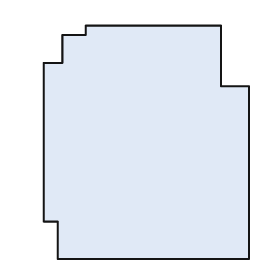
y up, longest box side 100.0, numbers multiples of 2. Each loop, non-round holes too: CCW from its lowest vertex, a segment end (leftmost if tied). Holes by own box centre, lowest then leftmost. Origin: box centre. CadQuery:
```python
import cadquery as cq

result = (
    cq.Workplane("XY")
    .moveTo(-38.0, -50.0)
    .lineTo(44.0, -50.0)
    .lineTo(44.0, 24.0)
    .lineTo(32.0, 24.0)
    .lineTo(32.0, 50.0)
    .lineTo(-26.0, 50.0)
    .lineTo(-26.0, 46.0)
    .lineTo(-36.0, 46.0)
    .lineTo(-36.0, 34.0)
    .lineTo(-44.0, 34.0)
    .lineTo(-44.0, -34.0)
    .lineTo(-38.0, -34.0)
    .close()
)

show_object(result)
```